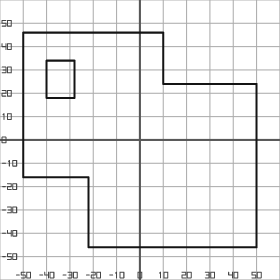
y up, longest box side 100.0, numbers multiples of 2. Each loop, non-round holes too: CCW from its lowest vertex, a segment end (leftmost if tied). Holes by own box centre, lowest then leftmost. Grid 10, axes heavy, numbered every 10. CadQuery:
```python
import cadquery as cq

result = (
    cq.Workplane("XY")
    .moveTo(-22.0, -46.0)
    .lineTo(50.0, -46.0)
    .lineTo(50.0, 24.0)
    .lineTo(10.0, 24.0)
    .lineTo(10.0, 46.0)
    .lineTo(-50.0, 46.0)
    .lineTo(-50.0, -16.0)
    .lineTo(-22.0, -16.0)
    .close()
    .moveTo(-40.0, 18.0)
    .lineTo(-28.0, 18.0)
    .lineTo(-28.0, 34.0)
    .lineTo(-40.0, 34.0)
    .close()
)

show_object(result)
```